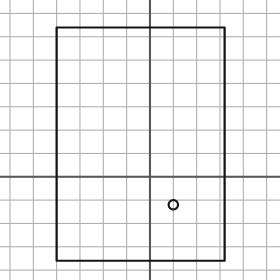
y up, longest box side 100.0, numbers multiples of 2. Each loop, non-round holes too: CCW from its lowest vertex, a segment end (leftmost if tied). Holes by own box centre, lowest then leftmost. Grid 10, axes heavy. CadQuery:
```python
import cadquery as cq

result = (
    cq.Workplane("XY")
    .moveTo(-40.0, -36.0)
    .lineTo(32.0, -36.0)
    .lineTo(32.0, 64.0)
    .lineTo(-40.0, 64.0)
    .close()
    .moveTo(10.0, -12.0)
    .circle(2.0)
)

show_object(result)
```